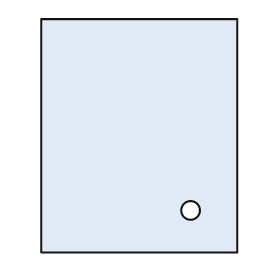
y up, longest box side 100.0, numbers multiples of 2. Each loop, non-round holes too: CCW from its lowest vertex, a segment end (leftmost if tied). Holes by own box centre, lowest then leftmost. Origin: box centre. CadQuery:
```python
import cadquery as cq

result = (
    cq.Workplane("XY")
    .moveTo(-42.0, -50.0)
    .lineTo(42.0, -50.0)
    .lineTo(42.0, 50.0)
    .lineTo(-42.0, 50.0)
    .close()
    .moveTo(22.0, -32.0)
    .circle(4.0)
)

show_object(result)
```